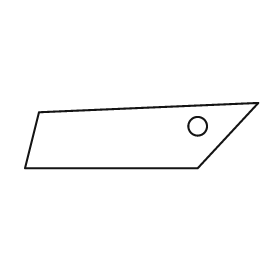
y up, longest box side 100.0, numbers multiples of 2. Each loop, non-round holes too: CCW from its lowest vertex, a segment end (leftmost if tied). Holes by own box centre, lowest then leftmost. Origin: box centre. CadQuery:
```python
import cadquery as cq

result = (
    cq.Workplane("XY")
    .moveTo(-50.0, -14.0)
    .lineTo(24.0, -14.0)
    .lineTo(50.0, 14.0)
    .lineTo(-44.0, 10.0)
    .close()
    .moveTo(24.0, 4.0)
    .circle(4.0)
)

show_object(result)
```